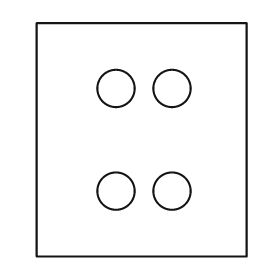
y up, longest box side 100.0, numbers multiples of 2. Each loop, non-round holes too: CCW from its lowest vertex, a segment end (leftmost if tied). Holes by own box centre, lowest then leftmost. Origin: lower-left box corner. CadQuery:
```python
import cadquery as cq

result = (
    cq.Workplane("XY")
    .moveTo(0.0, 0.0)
    .lineTo(90.0, 0.0)
    .lineTo(90.0, 100.0)
    .lineTo(0.0, 100.0)
    .close()
    .moveTo(34.0, 28.0)
    .circle(8.0)
    .moveTo(58.0, 28.0)
    .circle(8.0)
    .moveTo(34.0, 72.0)
    .circle(8.0)
    .moveTo(58.0, 72.0)
    .circle(8.0)
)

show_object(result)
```